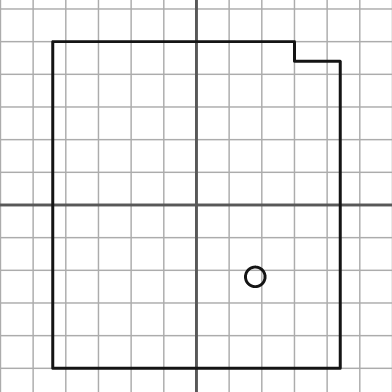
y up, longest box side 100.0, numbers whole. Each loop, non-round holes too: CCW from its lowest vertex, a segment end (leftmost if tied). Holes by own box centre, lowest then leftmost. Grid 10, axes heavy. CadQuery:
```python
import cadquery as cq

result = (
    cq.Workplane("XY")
    .moveTo(-44.0, -50.0)
    .lineTo(44.0, -50.0)
    .lineTo(44.0, 44.0)
    .lineTo(30.0, 44.0)
    .lineTo(30.0, 50.0)
    .lineTo(-44.0, 50.0)
    .close()
    .moveTo(18.0, -22.0)
    .circle(3.0)
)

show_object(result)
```